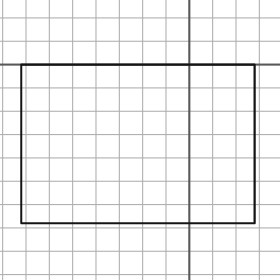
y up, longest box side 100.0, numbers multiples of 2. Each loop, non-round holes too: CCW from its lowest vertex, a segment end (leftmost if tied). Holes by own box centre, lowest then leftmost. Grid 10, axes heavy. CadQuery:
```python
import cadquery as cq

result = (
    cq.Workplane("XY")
    .moveTo(-72.0, -68.0)
    .lineTo(28.0, -68.0)
    .lineTo(28.0, 0.0)
    .lineTo(-72.0, 0.0)
    .close()
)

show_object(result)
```